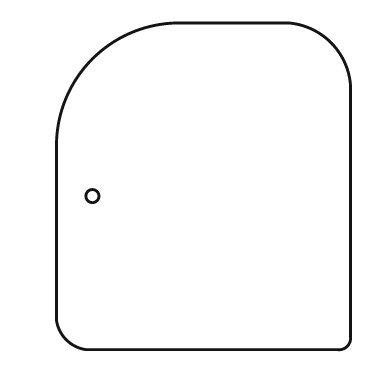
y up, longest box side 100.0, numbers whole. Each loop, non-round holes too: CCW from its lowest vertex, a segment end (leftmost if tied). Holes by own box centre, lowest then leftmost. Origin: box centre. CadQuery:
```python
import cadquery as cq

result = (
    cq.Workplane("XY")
    .moveTo(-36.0, -50.0)
    .lineTo(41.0, -50.0)
    .threePointArc((44.0, -49.0), (45.0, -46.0))
    .lineTo(45.0, 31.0)
    .threePointArc((39.0, 44.0), (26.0, 50.0))
    .lineTo(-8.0, 50.0)
    .threePointArc((-34.0, 39.0), (-45.0, 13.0))
    .lineTo(-45.0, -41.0)
    .threePointArc((-42.0, -47.0), (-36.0, -50.0))
    .close()
    .moveTo(-34.0, -3.0)
    .circle(2.0)
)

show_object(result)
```